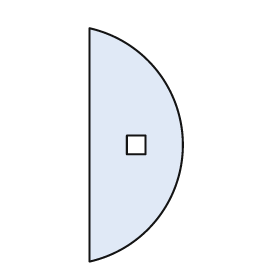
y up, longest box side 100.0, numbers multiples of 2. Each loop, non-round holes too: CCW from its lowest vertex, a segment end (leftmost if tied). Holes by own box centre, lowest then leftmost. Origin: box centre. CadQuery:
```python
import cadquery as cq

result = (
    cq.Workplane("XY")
    .moveTo(-20.0, -50.0)
    .threePointArc((20.0, 0.0), (-20.0, 50.0))
    .close()
    .moveTo(-4.0, -4.0)
    .lineTo(4.0, -4.0)
    .lineTo(4.0, 4.0)
    .lineTo(-4.0, 4.0)
    .close()
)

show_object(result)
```